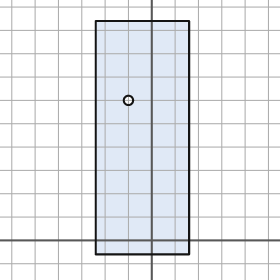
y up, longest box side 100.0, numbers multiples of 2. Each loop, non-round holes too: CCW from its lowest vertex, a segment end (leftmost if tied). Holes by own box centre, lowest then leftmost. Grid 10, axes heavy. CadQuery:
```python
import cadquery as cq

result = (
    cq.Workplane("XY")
    .moveTo(-24.0, -6.0)
    .lineTo(16.0, -6.0)
    .lineTo(16.0, 94.0)
    .lineTo(-24.0, 94.0)
    .close()
    .moveTo(-10.0, 60.0)
    .circle(2.0)
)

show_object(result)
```